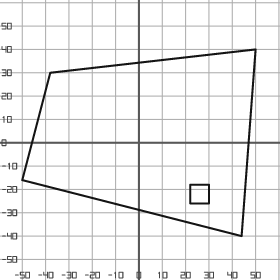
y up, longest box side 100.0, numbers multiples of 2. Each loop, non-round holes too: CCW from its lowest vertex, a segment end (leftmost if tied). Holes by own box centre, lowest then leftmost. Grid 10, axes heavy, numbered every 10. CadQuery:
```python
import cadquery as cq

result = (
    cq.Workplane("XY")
    .moveTo(44.0, -40.0)
    .lineTo(50.0, 40.0)
    .lineTo(-38.0, 30.0)
    .lineTo(-50.0, -16.0)
    .close()
    .moveTo(22.0, -26.0)
    .lineTo(30.0, -26.0)
    .lineTo(30.0, -18.0)
    .lineTo(22.0, -18.0)
    .close()
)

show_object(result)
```